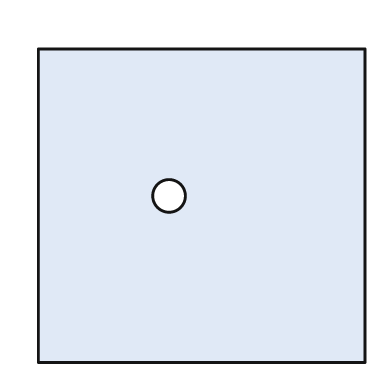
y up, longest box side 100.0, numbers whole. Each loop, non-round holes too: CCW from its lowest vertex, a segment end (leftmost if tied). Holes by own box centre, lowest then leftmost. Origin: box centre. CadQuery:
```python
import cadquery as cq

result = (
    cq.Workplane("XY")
    .moveTo(-50.0, -48.0)
    .lineTo(50.0, -48.0)
    .lineTo(50.0, 48.0)
    .lineTo(-50.0, 48.0)
    .close()
    .moveTo(-10.0, 3.0)
    .circle(5.0)
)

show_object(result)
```